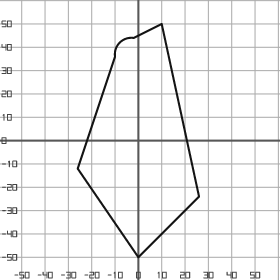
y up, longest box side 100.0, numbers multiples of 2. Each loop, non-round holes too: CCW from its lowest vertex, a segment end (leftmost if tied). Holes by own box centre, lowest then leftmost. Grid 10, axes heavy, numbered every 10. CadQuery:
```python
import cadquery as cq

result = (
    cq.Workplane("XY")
    .moveTo(0.0, -50.0)
    .lineTo(26.0, -24.0)
    .lineTo(10.0, 50.0)
    .lineTo(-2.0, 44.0)
    .threePointArc((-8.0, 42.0), (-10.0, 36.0))
    .lineTo(-26.0, -12.0)
    .close()
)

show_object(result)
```